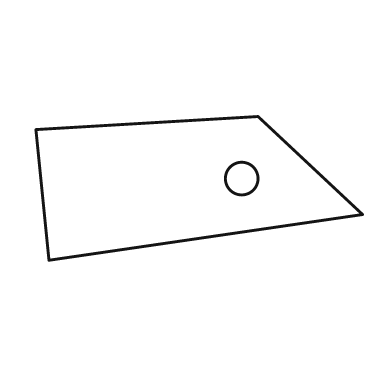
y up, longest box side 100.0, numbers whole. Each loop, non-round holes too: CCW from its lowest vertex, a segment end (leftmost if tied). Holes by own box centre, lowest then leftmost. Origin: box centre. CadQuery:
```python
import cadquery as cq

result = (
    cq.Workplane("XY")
    .moveTo(-46.0, -22.0)
    .lineTo(50.0, -8.0)
    .lineTo(18.0, 22.0)
    .lineTo(-50.0, 18.0)
    .close()
    .moveTo(13.0, 3.0)
    .circle(5.0)
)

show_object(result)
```